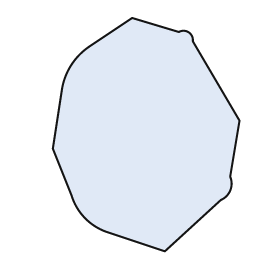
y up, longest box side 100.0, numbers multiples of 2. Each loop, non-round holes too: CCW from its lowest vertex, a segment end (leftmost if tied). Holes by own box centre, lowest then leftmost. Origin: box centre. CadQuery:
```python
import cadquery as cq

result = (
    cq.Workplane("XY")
    .moveTo(8.0, -50.0)
    .lineTo(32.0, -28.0)
    .threePointArc((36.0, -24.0), (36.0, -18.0))
    .lineTo(40.0, 6.0)
    .lineTo(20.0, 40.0)
    .threePointArc((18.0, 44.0), (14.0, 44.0))
    .lineTo(-6.0, 50.0)
    .lineTo(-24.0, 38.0)
    .threePointArc((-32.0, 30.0), (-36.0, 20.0))
    .lineTo(-40.0, -6.0)
    .lineTo(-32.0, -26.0)
    .threePointArc((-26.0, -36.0), (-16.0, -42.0))
    .close()
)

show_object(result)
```